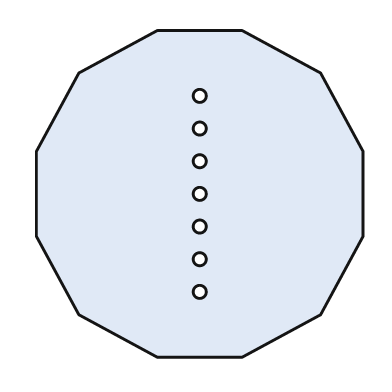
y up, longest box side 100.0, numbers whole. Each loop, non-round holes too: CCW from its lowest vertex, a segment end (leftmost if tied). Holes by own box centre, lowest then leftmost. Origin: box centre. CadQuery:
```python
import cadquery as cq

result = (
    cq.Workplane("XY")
    .moveTo(-13.0, -50.0)
    .lineTo(13.0, -50.0)
    .lineTo(37.0, -37.0)
    .lineTo(50.0, -13.0)
    .lineTo(50.0, 13.0)
    .lineTo(37.0, 37.0)
    .lineTo(13.0, 50.0)
    .lineTo(-13.0, 50.0)
    .lineTo(-37.0, 37.0)
    .lineTo(-50.0, 13.0)
    .lineTo(-50.0, -13.0)
    .lineTo(-37.0, -37.0)
    .close()
    .moveTo(0.0, -30.0)
    .circle(2.0)
    .moveTo(0.0, -20.0)
    .circle(2.0)
    .moveTo(0.0, -10.0)
    .circle(2.0)
    .moveTo(0.0, 0.0)
    .circle(2.0)
    .moveTo(0.0, 10.0)
    .circle(2.0)
    .moveTo(0.0, 20.0)
    .circle(2.0)
    .moveTo(0.0, 30.0)
    .circle(2.0)
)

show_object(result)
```